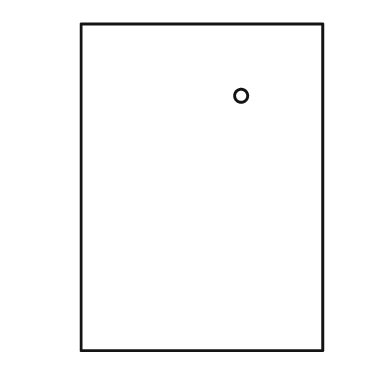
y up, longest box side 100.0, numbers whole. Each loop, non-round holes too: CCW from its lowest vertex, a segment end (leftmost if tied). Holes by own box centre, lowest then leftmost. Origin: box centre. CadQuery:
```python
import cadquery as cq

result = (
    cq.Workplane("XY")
    .moveTo(-37.0, -50.0)
    .lineTo(37.0, -50.0)
    .lineTo(37.0, 50.0)
    .lineTo(-37.0, 50.0)
    .close()
    .moveTo(12.0, 28.0)
    .circle(2.0)
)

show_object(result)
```